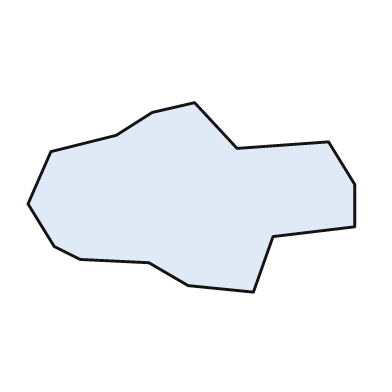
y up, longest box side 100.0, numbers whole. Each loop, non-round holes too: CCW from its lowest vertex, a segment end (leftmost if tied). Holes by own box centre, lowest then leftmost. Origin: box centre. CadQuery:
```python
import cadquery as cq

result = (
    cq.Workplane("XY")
    .moveTo(19.0, -29.0)
    .lineTo(25.0, -12.0)
    .lineTo(50.0, -9.0)
    .lineTo(50.0, 4.0)
    .lineTo(42.0, 17.0)
    .lineTo(14.0, 15.0)
    .lineTo(1.0, 29.0)
    .lineTo(-12.0, 26.0)
    .lineTo(-23.0, 19.0)
    .lineTo(-43.0, 14.0)
    .lineTo(-50.0, -2.0)
    .lineTo(-42.0, -15.0)
    .lineTo(-34.0, -19.0)
    .lineTo(-13.0, -20.0)
    .lineTo(-1.0, -27.0)
    .close()
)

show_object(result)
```